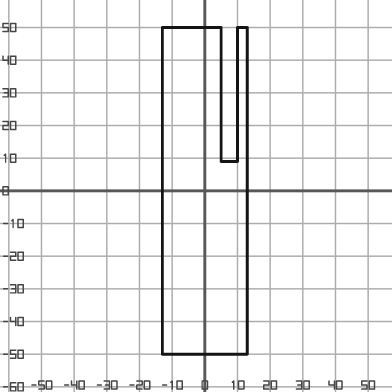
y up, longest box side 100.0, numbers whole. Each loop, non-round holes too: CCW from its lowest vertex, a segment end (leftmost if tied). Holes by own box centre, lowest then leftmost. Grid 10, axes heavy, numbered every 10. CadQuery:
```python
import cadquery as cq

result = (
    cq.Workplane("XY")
    .moveTo(-13.0, -50.0)
    .lineTo(13.0, -50.0)
    .lineTo(13.0, 50.0)
    .lineTo(10.0, 50.0)
    .lineTo(10.0, 9.0)
    .lineTo(5.0, 9.0)
    .lineTo(5.0, 50.0)
    .lineTo(-13.0, 50.0)
    .close()
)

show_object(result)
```